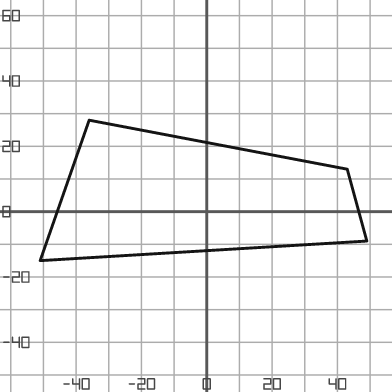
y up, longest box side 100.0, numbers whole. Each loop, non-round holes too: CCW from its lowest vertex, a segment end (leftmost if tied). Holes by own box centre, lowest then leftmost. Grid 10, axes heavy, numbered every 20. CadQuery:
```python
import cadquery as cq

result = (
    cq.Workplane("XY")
    .moveTo(-51.0, -15.0)
    .lineTo(49.0, -9.0)
    .lineTo(43.0, 13.0)
    .lineTo(-36.0, 28.0)
    .close()
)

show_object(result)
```